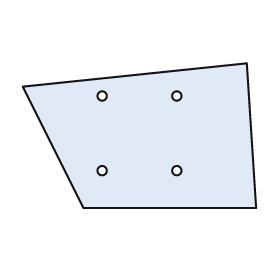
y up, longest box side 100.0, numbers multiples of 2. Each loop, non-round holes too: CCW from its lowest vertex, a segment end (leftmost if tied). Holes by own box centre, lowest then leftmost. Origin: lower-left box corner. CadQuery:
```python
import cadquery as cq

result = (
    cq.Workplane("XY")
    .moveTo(26.0, 0.0)
    .lineTo(100.0, 0.0)
    .lineTo(96.0, 62.0)
    .lineTo(0.0, 52.0)
    .close()
    .moveTo(34.0, 16.0)
    .circle(2.0)
    .moveTo(66.0, 16.0)
    .circle(2.0)
    .moveTo(34.0, 48.0)
    .circle(2.0)
    .moveTo(66.0, 48.0)
    .circle(2.0)
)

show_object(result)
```